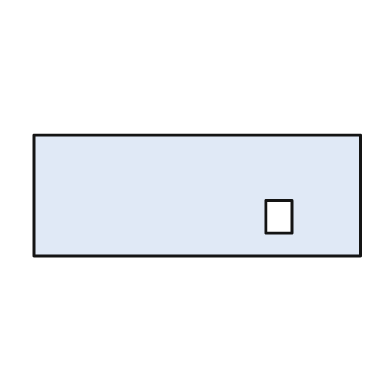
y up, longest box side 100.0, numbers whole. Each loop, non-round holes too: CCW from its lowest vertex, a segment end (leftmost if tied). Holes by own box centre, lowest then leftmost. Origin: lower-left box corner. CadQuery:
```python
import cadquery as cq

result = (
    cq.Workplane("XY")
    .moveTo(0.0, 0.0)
    .lineTo(100.0, 0.0)
    .lineTo(100.0, 37.0)
    .lineTo(0.0, 37.0)
    .close()
    .moveTo(71.0, 7.0)
    .lineTo(79.0, 7.0)
    .lineTo(79.0, 17.0)
    .lineTo(71.0, 17.0)
    .close()
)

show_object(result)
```